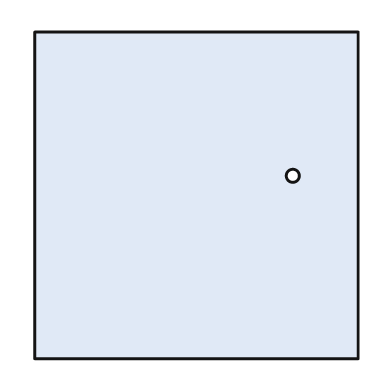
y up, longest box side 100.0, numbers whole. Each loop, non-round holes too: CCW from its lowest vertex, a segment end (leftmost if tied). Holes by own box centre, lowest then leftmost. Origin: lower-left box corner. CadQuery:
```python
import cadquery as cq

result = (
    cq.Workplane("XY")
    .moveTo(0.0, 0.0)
    .lineTo(99.0, 0.0)
    .lineTo(99.0, 100.0)
    .lineTo(0.0, 100.0)
    .close()
    .moveTo(79.0, 56.0)
    .circle(2.0)
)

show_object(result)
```